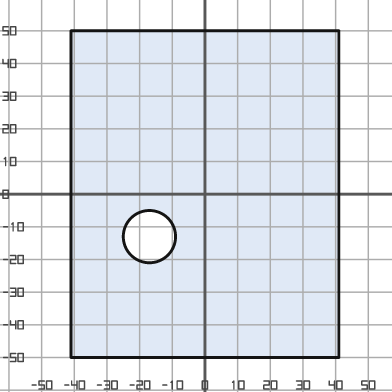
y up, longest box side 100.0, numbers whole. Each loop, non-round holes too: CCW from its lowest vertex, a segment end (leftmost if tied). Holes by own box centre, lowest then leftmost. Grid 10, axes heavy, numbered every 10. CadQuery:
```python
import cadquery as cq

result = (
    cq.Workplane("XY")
    .moveTo(-41.0, -50.0)
    .lineTo(41.0, -50.0)
    .lineTo(41.0, 50.0)
    .lineTo(-41.0, 50.0)
    .close()
    .moveTo(-17.0, -13.0)
    .circle(8.0)
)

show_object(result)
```